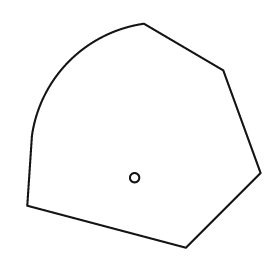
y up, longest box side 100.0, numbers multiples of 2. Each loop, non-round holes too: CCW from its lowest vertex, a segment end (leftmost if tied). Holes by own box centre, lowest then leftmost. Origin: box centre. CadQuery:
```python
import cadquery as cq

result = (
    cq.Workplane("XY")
    .moveTo(18.0, -48.0)
    .lineTo(50.0, -16.0)
    .lineTo(34.0, 28.0)
    .lineTo(0.0, 48.0)
    .threePointArc((-32.0, 32.0), (-48.0, 0.0))
    .lineTo(-50.0, -30.0)
    .close()
    .moveTo(-4.0, -18.0)
    .circle(2.0)
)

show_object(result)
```